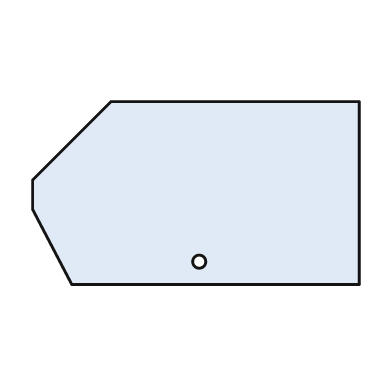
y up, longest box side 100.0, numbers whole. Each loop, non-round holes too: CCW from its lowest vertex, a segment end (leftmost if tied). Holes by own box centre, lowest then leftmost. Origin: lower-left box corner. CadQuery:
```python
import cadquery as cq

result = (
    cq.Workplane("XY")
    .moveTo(12.0, 0.0)
    .lineTo(100.0, 0.0)
    .lineTo(100.0, 56.0)
    .lineTo(24.0, 56.0)
    .lineTo(0.0, 32.0)
    .lineTo(0.0, 23.0)
    .close()
    .moveTo(51.0, 7.0)
    .circle(2.0)
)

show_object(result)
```